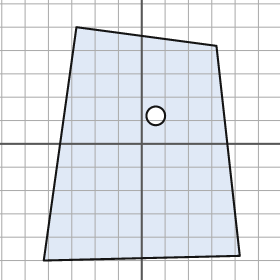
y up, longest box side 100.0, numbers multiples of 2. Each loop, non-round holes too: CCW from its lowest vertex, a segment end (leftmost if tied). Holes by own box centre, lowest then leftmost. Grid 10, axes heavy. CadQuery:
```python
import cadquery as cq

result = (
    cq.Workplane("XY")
    .moveTo(-42.0, -50.0)
    .lineTo(42.0, -48.0)
    .lineTo(32.0, 42.0)
    .lineTo(-28.0, 50.0)
    .close()
    .moveTo(6.0, 12.0)
    .circle(4.0)
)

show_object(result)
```